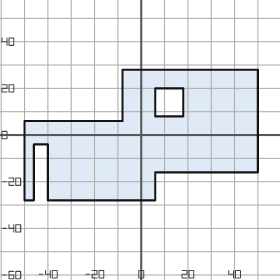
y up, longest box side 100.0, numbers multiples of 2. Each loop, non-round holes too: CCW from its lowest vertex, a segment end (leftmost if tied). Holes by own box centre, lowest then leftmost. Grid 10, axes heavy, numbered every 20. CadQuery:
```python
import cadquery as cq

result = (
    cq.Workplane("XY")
    .moveTo(-50.0, -28.0)
    .lineTo(-46.0, -28.0)
    .lineTo(-46.0, -4.0)
    .lineTo(-40.0, -4.0)
    .lineTo(-40.0, -28.0)
    .lineTo(6.0, -28.0)
    .lineTo(6.0, -16.0)
    .lineTo(50.0, -16.0)
    .lineTo(50.0, 28.0)
    .lineTo(-8.0, 28.0)
    .lineTo(-8.0, 6.0)
    .lineTo(-50.0, 6.0)
    .close()
    .moveTo(6.0, 8.0)
    .lineTo(18.0, 8.0)
    .lineTo(18.0, 20.0)
    .lineTo(6.0, 20.0)
    .close()
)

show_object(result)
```